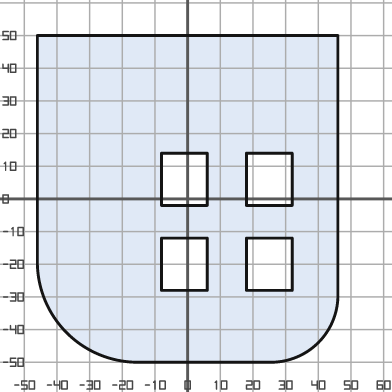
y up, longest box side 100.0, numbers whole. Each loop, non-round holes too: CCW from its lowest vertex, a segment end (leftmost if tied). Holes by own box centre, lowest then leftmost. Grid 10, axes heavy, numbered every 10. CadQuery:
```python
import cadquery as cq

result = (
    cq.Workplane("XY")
    .moveTo(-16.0, -50.0)
    .lineTo(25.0, -50.0)
    .threePointArc((40.0, -44.0), (46.0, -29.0))
    .lineTo(46.0, 50.0)
    .lineTo(-46.0, 50.0)
    .lineTo(-46.0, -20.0)
    .threePointArc((-37.0, -41.0), (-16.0, -50.0))
    .close()
    .moveTo(-8.0, -28.0)
    .lineTo(6.0, -28.0)
    .lineTo(6.0, -12.0)
    .lineTo(-8.0, -12.0)
    .close()
    .moveTo(18.0, -28.0)
    .lineTo(32.0, -28.0)
    .lineTo(32.0, -12.0)
    .lineTo(18.0, -12.0)
    .close()
    .moveTo(-8.0, -2.0)
    .lineTo(6.0, -2.0)
    .lineTo(6.0, 14.0)
    .lineTo(-8.0, 14.0)
    .close()
    .moveTo(18.0, -2.0)
    .lineTo(32.0, -2.0)
    .lineTo(32.0, 14.0)
    .lineTo(18.0, 14.0)
    .close()
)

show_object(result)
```